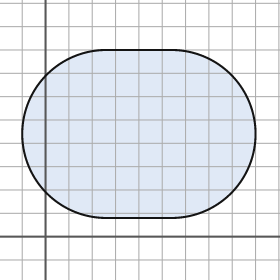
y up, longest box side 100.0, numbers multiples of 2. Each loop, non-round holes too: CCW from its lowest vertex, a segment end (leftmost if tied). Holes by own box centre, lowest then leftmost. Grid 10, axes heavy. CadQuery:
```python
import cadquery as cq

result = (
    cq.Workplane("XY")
    .moveTo(26.0, 8.0)
    .lineTo(54.0, 8.0)
    .threePointArc((90.0, 44.0), (54.0, 80.0))
    .lineTo(26.0, 80.0)
    .threePointArc((-10.0, 44.0), (26.0, 8.0))
    .close()
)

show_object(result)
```